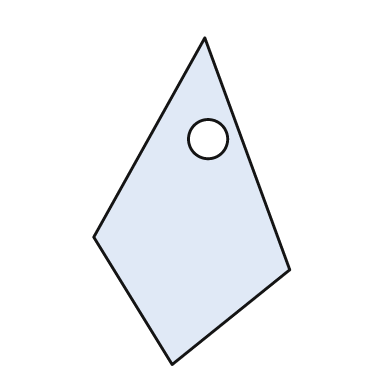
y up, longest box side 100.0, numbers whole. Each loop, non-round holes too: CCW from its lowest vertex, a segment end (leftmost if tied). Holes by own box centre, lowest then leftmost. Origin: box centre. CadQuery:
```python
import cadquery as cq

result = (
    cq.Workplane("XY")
    .moveTo(-6.0, -50.0)
    .lineTo(30.0, -21.0)
    .lineTo(4.0, 50.0)
    .lineTo(-30.0, -11.0)
    .close()
    .moveTo(5.0, 19.0)
    .circle(6.0)
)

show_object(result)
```